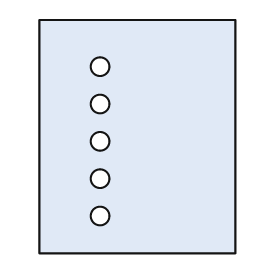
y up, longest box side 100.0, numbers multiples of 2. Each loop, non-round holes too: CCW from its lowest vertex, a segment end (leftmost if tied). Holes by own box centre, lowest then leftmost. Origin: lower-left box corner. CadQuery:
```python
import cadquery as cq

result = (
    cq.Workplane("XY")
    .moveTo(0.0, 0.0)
    .lineTo(84.0, 0.0)
    .lineTo(84.0, 100.0)
    .lineTo(0.0, 100.0)
    .close()
    .moveTo(26.0, 16.0)
    .circle(4.0)
    .moveTo(26.0, 32.0)
    .circle(4.0)
    .moveTo(26.0, 48.0)
    .circle(4.0)
    .moveTo(26.0, 64.0)
    .circle(4.0)
    .moveTo(26.0, 80.0)
    .circle(4.0)
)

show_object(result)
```